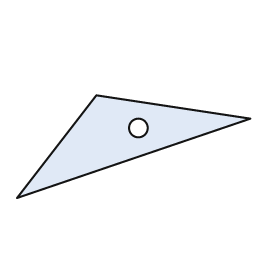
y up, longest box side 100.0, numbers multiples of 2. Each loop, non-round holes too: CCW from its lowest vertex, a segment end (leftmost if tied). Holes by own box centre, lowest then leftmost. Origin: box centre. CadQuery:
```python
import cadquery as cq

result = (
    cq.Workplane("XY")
    .moveTo(-50.0, -22.0)
    .lineTo(50.0, 12.0)
    .lineTo(-16.0, 22.0)
    .close()
    .moveTo(2.0, 8.0)
    .circle(4.0)
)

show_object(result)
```